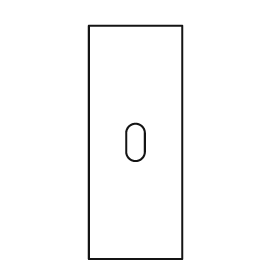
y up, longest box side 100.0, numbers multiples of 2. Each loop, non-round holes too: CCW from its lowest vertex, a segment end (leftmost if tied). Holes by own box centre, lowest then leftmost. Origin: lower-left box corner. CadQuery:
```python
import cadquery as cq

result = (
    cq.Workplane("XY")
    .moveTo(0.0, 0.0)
    .lineTo(40.0, 0.0)
    .lineTo(40.0, 100.0)
    .lineTo(0.0, 100.0)
    .close()
    .moveTo(16.0, 46.0)
    .threePointArc((20.0, 42.0), (24.0, 46.0))
    .lineTo(24.0, 54.0)
    .threePointArc((20.0, 58.0), (16.0, 54.0))
    .close()
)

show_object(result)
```